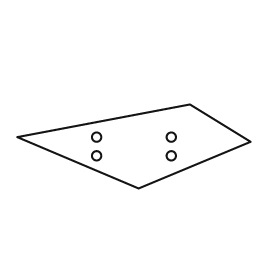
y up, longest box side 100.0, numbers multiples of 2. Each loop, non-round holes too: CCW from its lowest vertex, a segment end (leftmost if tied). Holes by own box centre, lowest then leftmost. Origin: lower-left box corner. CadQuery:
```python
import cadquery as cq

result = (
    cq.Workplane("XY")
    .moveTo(52.0, 0.0)
    .lineTo(100.0, 20.0)
    .lineTo(74.0, 36.0)
    .lineTo(0.0, 22.0)
    .close()
    .moveTo(34.0, 14.0)
    .circle(2.0)
    .moveTo(66.0, 14.0)
    .circle(2.0)
    .moveTo(34.0, 22.0)
    .circle(2.0)
    .moveTo(66.0, 22.0)
    .circle(2.0)
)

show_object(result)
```